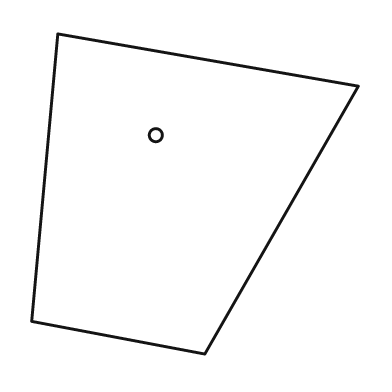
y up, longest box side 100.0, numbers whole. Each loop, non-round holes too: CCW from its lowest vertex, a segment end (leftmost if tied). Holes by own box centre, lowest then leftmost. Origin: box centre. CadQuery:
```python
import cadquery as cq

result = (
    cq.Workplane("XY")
    .moveTo(3.0, -49.0)
    .lineTo(50.0, 33.0)
    .lineTo(-42.0, 49.0)
    .lineTo(-50.0, -39.0)
    .close()
    .moveTo(-12.0, 18.0)
    .circle(2.0)
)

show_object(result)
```